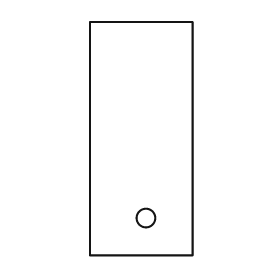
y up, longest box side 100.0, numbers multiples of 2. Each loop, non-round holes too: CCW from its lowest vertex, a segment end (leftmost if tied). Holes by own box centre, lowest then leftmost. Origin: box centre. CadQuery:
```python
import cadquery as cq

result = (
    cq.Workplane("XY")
    .moveTo(-22.0, -50.0)
    .lineTo(22.0, -50.0)
    .lineTo(22.0, 50.0)
    .lineTo(-22.0, 50.0)
    .close()
    .moveTo(2.0, -34.0)
    .circle(4.0)
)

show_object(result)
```